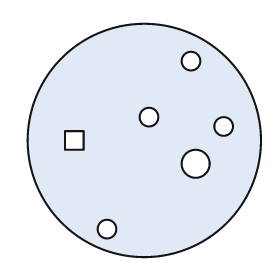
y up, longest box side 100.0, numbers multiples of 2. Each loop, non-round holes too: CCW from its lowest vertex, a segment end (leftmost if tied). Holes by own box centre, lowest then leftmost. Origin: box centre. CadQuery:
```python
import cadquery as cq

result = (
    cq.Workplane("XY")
    .moveTo(0.0, 0.0)
    .circle(50.0)
    .moveTo(-16.0, -38.0)
    .circle(4.0)
    .moveTo(22.0, -10.0)
    .circle(6.0)
    .moveTo(-34.0, -4.0)
    .lineTo(-26.0, -4.0)
    .lineTo(-26.0, 4.0)
    .lineTo(-34.0, 4.0)
    .close()
    .moveTo(34.0, 6.0)
    .circle(4.0)
    .moveTo(2.0, 10.0)
    .circle(4.0)
    .moveTo(20.0, 34.0)
    .circle(4.0)
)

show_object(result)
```